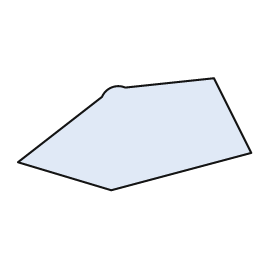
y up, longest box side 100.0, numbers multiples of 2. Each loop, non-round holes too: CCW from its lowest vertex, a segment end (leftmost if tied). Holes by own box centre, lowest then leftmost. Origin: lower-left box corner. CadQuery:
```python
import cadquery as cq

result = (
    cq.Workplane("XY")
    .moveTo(40.0, 0.0)
    .lineTo(100.0, 16.0)
    .lineTo(84.0, 48.0)
    .lineTo(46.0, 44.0)
    .threePointArc((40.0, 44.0), (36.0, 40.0))
    .lineTo(0.0, 12.0)
    .close()
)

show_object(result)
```